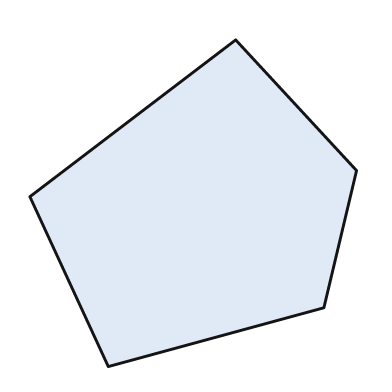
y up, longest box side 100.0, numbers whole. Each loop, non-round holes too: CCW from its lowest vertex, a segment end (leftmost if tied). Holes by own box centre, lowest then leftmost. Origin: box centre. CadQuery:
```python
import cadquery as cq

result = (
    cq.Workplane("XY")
    .moveTo(-26.0, -50.0)
    .lineTo(40.0, -32.0)
    .lineTo(50.0, 10.0)
    .lineTo(13.0, 50.0)
    .lineTo(-50.0, 2.0)
    .close()
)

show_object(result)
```